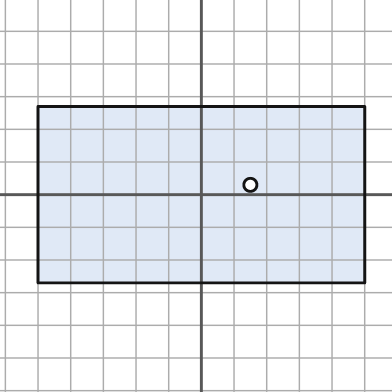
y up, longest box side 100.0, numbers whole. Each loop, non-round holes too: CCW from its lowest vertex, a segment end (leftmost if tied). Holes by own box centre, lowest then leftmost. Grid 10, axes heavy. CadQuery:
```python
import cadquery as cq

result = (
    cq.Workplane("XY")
    .moveTo(-50.0, -27.0)
    .lineTo(50.0, -27.0)
    .lineTo(50.0, 27.0)
    .lineTo(-50.0, 27.0)
    .close()
    .moveTo(15.0, 3.0)
    .circle(2.0)
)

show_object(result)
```